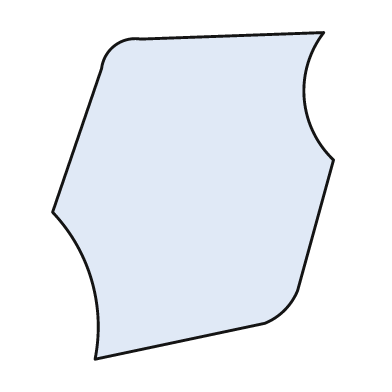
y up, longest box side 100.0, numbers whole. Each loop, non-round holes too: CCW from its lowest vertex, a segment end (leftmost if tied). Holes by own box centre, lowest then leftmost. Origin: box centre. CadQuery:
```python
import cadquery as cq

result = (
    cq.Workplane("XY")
    .moveTo(-30.0, -50.0)
    .lineTo(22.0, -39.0)
    .threePointArc((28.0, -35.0), (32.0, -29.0))
    .lineTo(43.0, 11.0)
    .threePointArc((34.0, 30.0), (40.0, 50.0))
    .lineTo(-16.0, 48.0)
    .threePointArc((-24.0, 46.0), (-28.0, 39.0))
    .lineTo(-43.0, -5.0)
    .threePointArc((-31.0, -26.0), (-30.0, -50.0))
    .close()
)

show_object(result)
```